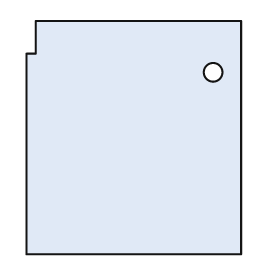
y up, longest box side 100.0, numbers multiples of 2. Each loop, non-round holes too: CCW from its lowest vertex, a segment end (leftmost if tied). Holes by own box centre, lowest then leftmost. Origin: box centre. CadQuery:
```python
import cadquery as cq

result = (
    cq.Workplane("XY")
    .moveTo(-46.0, -50.0)
    .lineTo(46.0, -50.0)
    .lineTo(46.0, 50.0)
    .lineTo(-42.0, 50.0)
    .lineTo(-42.0, 36.0)
    .lineTo(-46.0, 36.0)
    .close()
    .moveTo(34.0, 28.0)
    .circle(4.0)
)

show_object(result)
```